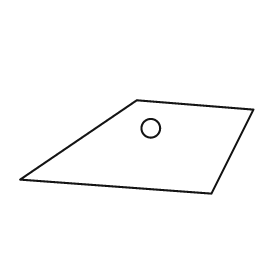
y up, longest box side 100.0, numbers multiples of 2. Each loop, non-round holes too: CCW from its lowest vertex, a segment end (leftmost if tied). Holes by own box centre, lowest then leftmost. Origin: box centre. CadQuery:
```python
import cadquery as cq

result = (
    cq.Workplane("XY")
    .moveTo(32.0, -20.0)
    .lineTo(50.0, 16.0)
    .lineTo(0.0, 20.0)
    .lineTo(-50.0, -14.0)
    .close()
    .moveTo(6.0, 8.0)
    .circle(4.0)
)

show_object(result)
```